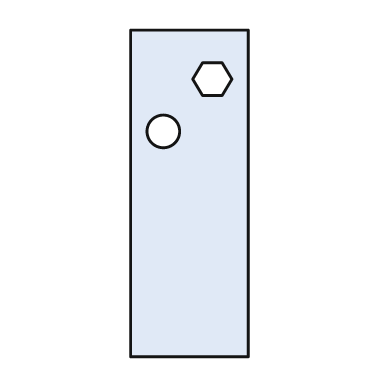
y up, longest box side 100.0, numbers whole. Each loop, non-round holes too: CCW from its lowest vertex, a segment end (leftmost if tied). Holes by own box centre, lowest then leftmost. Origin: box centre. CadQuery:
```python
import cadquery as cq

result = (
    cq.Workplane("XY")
    .moveTo(-18.0, -50.0)
    .lineTo(18.0, -50.0)
    .lineTo(18.0, 50.0)
    .lineTo(-18.0, 50.0)
    .close()
    .moveTo(-8.0, 19.0)
    .circle(5.0)
    .moveTo(4.0, 30.0)
    .lineTo(10.0, 30.0)
    .lineTo(13.0, 35.0)
    .lineTo(10.0, 40.0)
    .lineTo(4.0, 40.0)
    .lineTo(1.0, 35.0)
    .close()
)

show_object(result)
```